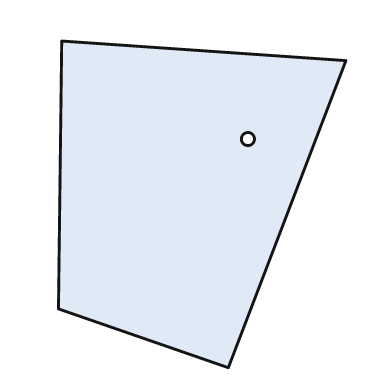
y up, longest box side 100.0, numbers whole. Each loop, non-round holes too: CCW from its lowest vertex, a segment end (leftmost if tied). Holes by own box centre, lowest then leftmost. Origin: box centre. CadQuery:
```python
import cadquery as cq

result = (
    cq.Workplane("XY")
    .moveTo(8.0, -50.0)
    .lineTo(44.0, 44.0)
    .lineTo(-43.0, 50.0)
    .lineTo(-44.0, -32.0)
    .close()
    .moveTo(14.0, 20.0)
    .circle(2.0)
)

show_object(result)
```